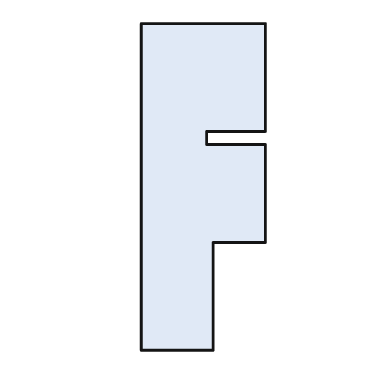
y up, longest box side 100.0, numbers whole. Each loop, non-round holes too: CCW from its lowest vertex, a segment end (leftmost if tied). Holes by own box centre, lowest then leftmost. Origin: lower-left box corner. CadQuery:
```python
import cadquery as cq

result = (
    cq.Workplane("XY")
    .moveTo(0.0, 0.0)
    .lineTo(22.0, 0.0)
    .lineTo(22.0, 33.0)
    .lineTo(38.0, 33.0)
    .lineTo(38.0, 63.0)
    .lineTo(20.0, 63.0)
    .lineTo(20.0, 67.0)
    .lineTo(38.0, 67.0)
    .lineTo(38.0, 100.0)
    .lineTo(0.0, 100.0)
    .close()
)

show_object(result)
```